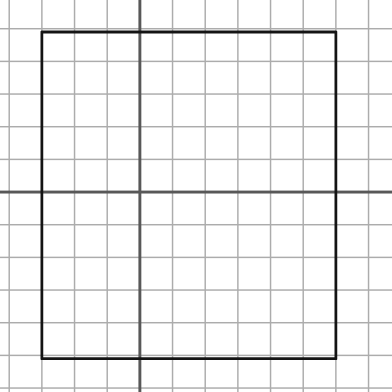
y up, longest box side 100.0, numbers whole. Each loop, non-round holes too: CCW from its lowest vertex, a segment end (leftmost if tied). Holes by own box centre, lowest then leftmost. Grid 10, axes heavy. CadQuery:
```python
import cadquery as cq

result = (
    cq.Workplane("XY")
    .moveTo(-30.0, -51.0)
    .lineTo(60.0, -51.0)
    .lineTo(60.0, 49.0)
    .lineTo(-30.0, 49.0)
    .close()
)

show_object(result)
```